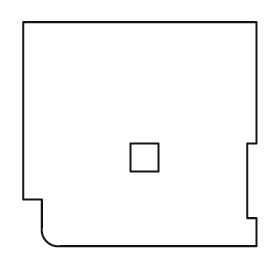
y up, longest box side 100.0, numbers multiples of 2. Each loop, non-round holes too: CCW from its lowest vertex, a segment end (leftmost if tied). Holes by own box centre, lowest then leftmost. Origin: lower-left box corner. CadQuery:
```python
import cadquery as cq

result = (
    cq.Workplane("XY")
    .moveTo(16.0, 0.0)
    .lineTo(100.0, 0.0)
    .lineTo(100.0, 12.0)
    .lineTo(96.0, 12.0)
    .lineTo(96.0, 44.0)
    .lineTo(100.0, 44.0)
    .lineTo(100.0, 96.0)
    .lineTo(0.0, 96.0)
    .lineTo(0.0, 20.0)
    .lineTo(8.0, 20.0)
    .lineTo(8.0, 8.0)
    .threePointArc((10.0, 2.0), (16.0, 0.0))
    .close()
    .moveTo(46.0, 32.0)
    .lineTo(58.0, 32.0)
    .lineTo(58.0, 44.0)
    .lineTo(46.0, 44.0)
    .close()
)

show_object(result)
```